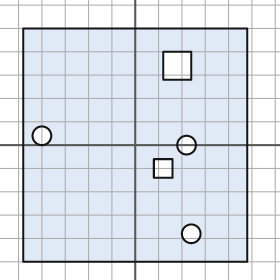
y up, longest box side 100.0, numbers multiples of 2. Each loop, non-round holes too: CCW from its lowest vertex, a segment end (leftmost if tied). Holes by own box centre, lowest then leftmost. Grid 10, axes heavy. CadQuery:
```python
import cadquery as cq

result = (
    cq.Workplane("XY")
    .moveTo(-48.0, -50.0)
    .lineTo(48.0, -50.0)
    .lineTo(48.0, 50.0)
    .lineTo(-48.0, 50.0)
    .close()
    .moveTo(24.0, -38.0)
    .circle(4.0)
    .moveTo(8.0, -14.0)
    .lineTo(16.0, -14.0)
    .lineTo(16.0, -6.0)
    .lineTo(8.0, -6.0)
    .close()
    .moveTo(22.0, 0.0)
    .circle(4.0)
    .moveTo(-40.0, 4.0)
    .circle(4.0)
    .moveTo(12.0, 28.0)
    .lineTo(24.0, 28.0)
    .lineTo(24.0, 40.0)
    .lineTo(12.0, 40.0)
    .close()
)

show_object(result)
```